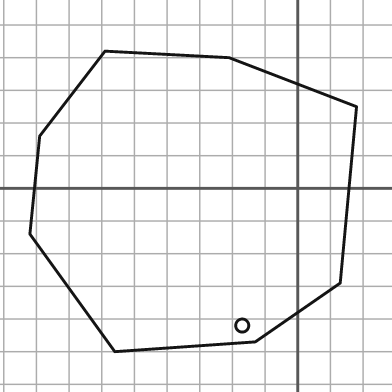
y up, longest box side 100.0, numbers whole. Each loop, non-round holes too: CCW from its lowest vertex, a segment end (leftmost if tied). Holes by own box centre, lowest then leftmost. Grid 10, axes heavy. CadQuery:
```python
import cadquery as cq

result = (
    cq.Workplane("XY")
    .moveTo(-56.0, -50.0)
    .lineTo(-13.0, -47.0)
    .lineTo(13.0, -29.0)
    .lineTo(18.0, 25.0)
    .lineTo(-21.0, 40.0)
    .lineTo(-59.0, 42.0)
    .lineTo(-79.0, 16.0)
    .lineTo(-82.0, -14.0)
    .close()
    .moveTo(-17.0, -42.0)
    .circle(2.0)
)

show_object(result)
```